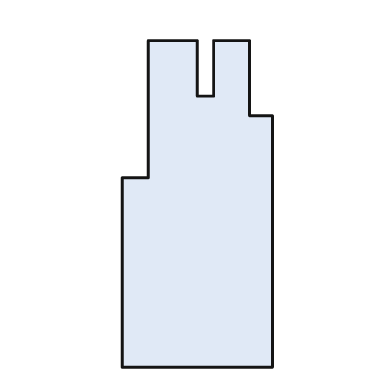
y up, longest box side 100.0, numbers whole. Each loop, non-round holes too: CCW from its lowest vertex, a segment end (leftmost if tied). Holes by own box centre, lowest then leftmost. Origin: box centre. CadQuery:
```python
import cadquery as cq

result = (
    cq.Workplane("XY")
    .moveTo(-23.0, -50.0)
    .lineTo(23.0, -50.0)
    .lineTo(23.0, 27.0)
    .lineTo(16.0, 27.0)
    .lineTo(16.0, 50.0)
    .lineTo(5.0, 50.0)
    .lineTo(5.0, 33.0)
    .lineTo(0.0, 33.0)
    .lineTo(0.0, 50.0)
    .lineTo(-15.0, 50.0)
    .lineTo(-15.0, 8.0)
    .lineTo(-23.0, 8.0)
    .close()
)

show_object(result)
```